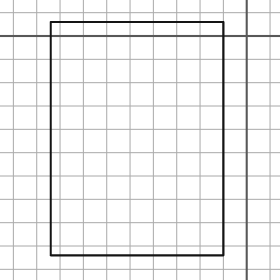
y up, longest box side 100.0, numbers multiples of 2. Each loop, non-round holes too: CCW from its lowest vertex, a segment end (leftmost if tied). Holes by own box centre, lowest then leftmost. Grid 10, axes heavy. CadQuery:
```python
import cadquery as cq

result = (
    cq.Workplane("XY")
    .moveTo(-84.0, -94.0)
    .lineTo(-10.0, -94.0)
    .lineTo(-10.0, 6.0)
    .lineTo(-84.0, 6.0)
    .close()
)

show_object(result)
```